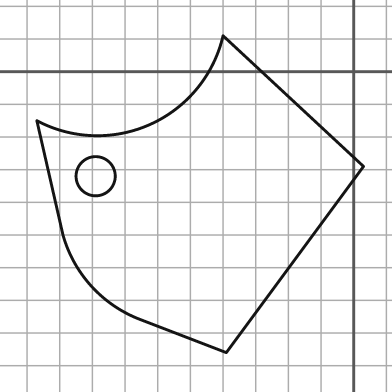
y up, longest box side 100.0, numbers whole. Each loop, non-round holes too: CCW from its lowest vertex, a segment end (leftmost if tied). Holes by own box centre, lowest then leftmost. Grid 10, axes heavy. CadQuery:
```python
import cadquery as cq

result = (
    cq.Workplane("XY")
    .moveTo(-39.0, -86.0)
    .lineTo(3.0, -29.0)
    .lineTo(-40.0, 11.0)
    .threePointArc((-62.0, -16.0), (-97.0, -15.0))
    .lineTo(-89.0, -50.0)
    .threePointArc((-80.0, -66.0), (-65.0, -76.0))
    .close()
    .moveTo(-79.0, -32.0)
    .circle(6.0)
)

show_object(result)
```